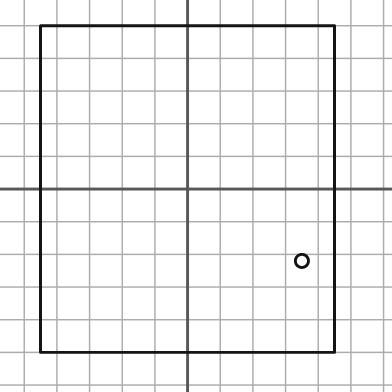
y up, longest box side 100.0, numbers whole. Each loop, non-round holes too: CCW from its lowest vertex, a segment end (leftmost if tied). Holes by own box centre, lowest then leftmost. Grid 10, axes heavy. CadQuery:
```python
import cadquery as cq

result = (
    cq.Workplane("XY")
    .moveTo(-45.0, -50.0)
    .lineTo(45.0, -50.0)
    .lineTo(45.0, 50.0)
    .lineTo(-45.0, 50.0)
    .close()
    .moveTo(35.0, -22.0)
    .circle(2.0)
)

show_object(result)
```